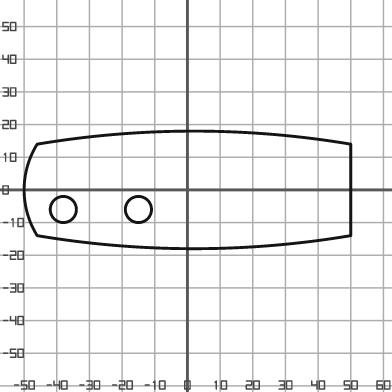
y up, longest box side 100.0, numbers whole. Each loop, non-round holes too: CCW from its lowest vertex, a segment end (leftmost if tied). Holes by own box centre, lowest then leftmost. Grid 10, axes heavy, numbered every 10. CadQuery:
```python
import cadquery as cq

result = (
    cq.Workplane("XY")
    .moveTo(-46.0, -14.0)
    .threePointArc((2.0, -18.0), (50.0, -14.0))
    .lineTo(50.0, 14.0)
    .threePointArc((2.0, 18.0), (-46.0, 14.0))
    .threePointArc((-50.0, 0.0), (-46.0, -14.0))
    .close()
    .moveTo(-38.0, -6.0)
    .circle(4.0)
    .moveTo(-15.0, -6.0)
    .circle(4.0)
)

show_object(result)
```